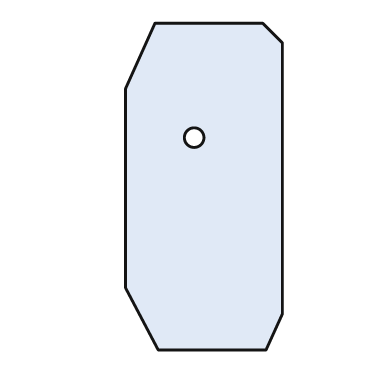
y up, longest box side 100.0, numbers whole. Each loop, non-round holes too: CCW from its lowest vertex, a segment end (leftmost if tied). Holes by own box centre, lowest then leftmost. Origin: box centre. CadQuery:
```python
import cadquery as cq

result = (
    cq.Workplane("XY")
    .moveTo(-14.0, -50.0)
    .lineTo(19.0, -50.0)
    .lineTo(24.0, -39.0)
    .lineTo(24.0, 44.0)
    .lineTo(18.0, 50.0)
    .lineTo(-15.0, 50.0)
    .lineTo(-24.0, 30.0)
    .lineTo(-24.0, -31.0)
    .close()
    .moveTo(-3.0, 15.0)
    .circle(3.0)
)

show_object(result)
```